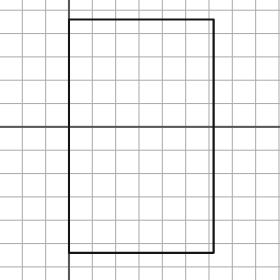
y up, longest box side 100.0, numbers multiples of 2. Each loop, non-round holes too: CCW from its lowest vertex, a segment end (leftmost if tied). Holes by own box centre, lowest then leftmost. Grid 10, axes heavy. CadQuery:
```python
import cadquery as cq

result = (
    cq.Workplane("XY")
    .moveTo(0.0, -54.0)
    .lineTo(62.0, -54.0)
    .lineTo(62.0, 46.0)
    .lineTo(0.0, 46.0)
    .close()
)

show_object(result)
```